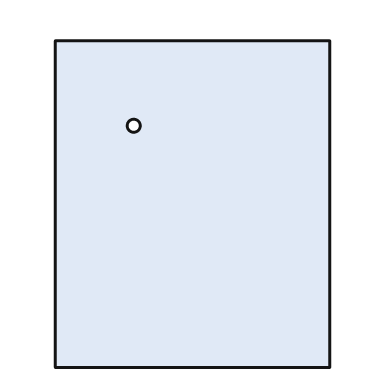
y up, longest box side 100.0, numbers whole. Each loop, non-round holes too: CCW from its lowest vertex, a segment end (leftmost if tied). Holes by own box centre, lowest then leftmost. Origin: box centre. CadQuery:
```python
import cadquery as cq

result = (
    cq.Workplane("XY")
    .moveTo(-42.0, -50.0)
    .lineTo(42.0, -50.0)
    .lineTo(42.0, 50.0)
    .lineTo(-42.0, 50.0)
    .close()
    .moveTo(-18.0, 24.0)
    .circle(2.0)
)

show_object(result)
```